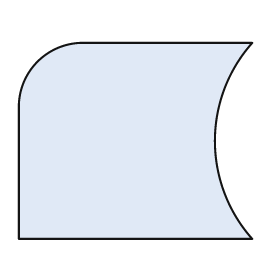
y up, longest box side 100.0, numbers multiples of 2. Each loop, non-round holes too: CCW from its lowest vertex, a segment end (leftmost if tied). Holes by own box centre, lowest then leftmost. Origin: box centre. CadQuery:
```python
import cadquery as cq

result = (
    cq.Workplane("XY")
    .moveTo(-50.0, -42.0)
    .lineTo(50.0, -42.0)
    .threePointArc((34.0, 0.0), (50.0, 42.0))
    .lineTo(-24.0, 42.0)
    .threePointArc((-42.0, 34.0), (-50.0, 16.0))
    .close()
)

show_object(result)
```